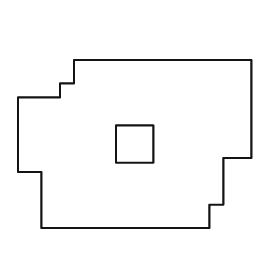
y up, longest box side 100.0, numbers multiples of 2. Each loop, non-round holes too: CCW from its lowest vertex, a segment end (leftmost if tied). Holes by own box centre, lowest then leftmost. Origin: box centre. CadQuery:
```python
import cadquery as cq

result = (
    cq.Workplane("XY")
    .moveTo(-40.0, -36.0)
    .lineTo(32.0, -36.0)
    .lineTo(32.0, -26.0)
    .lineTo(38.0, -26.0)
    .lineTo(38.0, -6.0)
    .lineTo(50.0, -6.0)
    .lineTo(50.0, 36.0)
    .lineTo(-26.0, 36.0)
    .lineTo(-26.0, 26.0)
    .lineTo(-32.0, 26.0)
    .lineTo(-32.0, 20.0)
    .lineTo(-50.0, 20.0)
    .lineTo(-50.0, -12.0)
    .lineTo(-40.0, -12.0)
    .close()
    .moveTo(-8.0, -8.0)
    .lineTo(8.0, -8.0)
    .lineTo(8.0, 8.0)
    .lineTo(-8.0, 8.0)
    .close()
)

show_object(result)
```